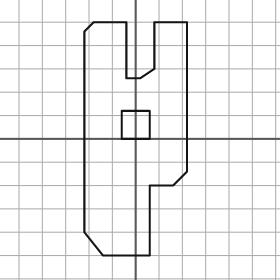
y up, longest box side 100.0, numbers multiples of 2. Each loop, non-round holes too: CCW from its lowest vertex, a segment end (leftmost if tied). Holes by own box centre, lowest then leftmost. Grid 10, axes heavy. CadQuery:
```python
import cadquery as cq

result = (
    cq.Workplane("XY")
    .moveTo(-14.0, -50.0)
    .lineTo(6.0, -50.0)
    .lineTo(6.0, -20.0)
    .lineTo(16.0, -20.0)
    .lineTo(22.0, -14.0)
    .lineTo(22.0, 50.0)
    .lineTo(8.0, 50.0)
    .lineTo(8.0, 30.0)
    .lineTo(2.0, 26.0)
    .lineTo(-4.0, 26.0)
    .lineTo(-4.0, 50.0)
    .lineTo(-18.0, 50.0)
    .lineTo(-22.0, 46.0)
    .lineTo(-22.0, -40.0)
    .close()
    .moveTo(-6.0, 0.0)
    .lineTo(6.0, 0.0)
    .lineTo(6.0, 12.0)
    .lineTo(-6.0, 12.0)
    .close()
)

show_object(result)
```